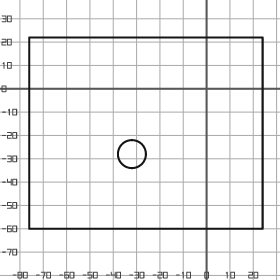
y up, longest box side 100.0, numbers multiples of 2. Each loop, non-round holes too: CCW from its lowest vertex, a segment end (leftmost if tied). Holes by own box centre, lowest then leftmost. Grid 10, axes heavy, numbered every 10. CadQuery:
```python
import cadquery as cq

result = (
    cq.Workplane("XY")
    .moveTo(-76.0, -60.0)
    .lineTo(24.0, -60.0)
    .lineTo(24.0, 22.0)
    .lineTo(-76.0, 22.0)
    .close()
    .moveTo(-32.0, -28.0)
    .circle(6.0)
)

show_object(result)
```